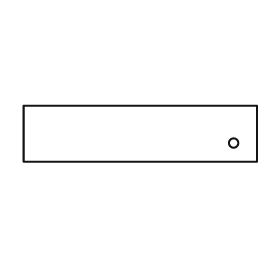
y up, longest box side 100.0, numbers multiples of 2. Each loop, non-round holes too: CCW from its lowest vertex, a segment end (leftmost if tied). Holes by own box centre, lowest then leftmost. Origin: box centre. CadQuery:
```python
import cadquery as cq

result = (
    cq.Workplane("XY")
    .moveTo(-50.0, -12.0)
    .lineTo(50.0, -12.0)
    .lineTo(50.0, 12.0)
    .lineTo(-50.0, 12.0)
    .close()
    .moveTo(40.0, -4.0)
    .circle(2.0)
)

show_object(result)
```